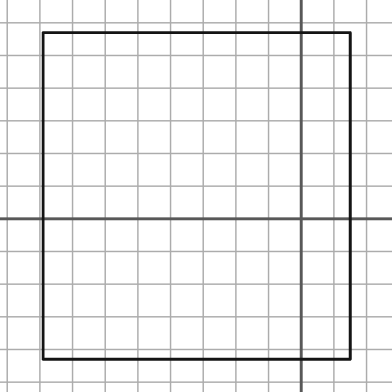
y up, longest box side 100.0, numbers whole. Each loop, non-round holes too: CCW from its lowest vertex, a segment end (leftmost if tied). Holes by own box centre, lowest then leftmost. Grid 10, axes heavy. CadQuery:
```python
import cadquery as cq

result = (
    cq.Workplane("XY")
    .moveTo(-79.0, -43.0)
    .lineTo(15.0, -43.0)
    .lineTo(15.0, 57.0)
    .lineTo(-79.0, 57.0)
    .close()
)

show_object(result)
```